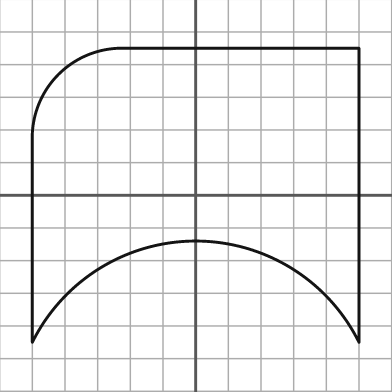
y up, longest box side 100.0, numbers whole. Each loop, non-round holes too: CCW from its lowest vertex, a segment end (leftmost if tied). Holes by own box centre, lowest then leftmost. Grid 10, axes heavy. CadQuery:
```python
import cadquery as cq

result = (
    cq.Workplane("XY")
    .moveTo(-50.0, -45.0)
    .threePointArc((0.0, -14.0), (50.0, -45.0))
    .lineTo(50.0, 45.0)
    .lineTo(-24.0, 45.0)
    .threePointArc((-42.0, 37.0), (-50.0, 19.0))
    .close()
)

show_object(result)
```